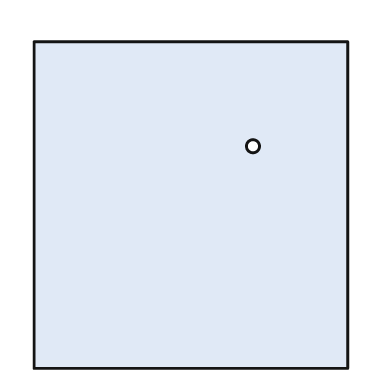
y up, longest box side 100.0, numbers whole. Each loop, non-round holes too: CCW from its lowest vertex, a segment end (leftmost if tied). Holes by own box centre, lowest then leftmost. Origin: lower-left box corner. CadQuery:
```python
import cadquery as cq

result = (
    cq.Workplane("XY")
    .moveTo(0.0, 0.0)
    .lineTo(96.0, 0.0)
    .lineTo(96.0, 100.0)
    .lineTo(0.0, 100.0)
    .close()
    .moveTo(67.0, 68.0)
    .circle(2.0)
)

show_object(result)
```